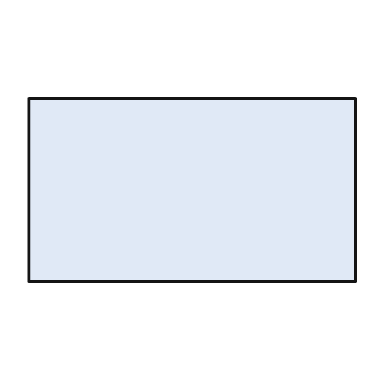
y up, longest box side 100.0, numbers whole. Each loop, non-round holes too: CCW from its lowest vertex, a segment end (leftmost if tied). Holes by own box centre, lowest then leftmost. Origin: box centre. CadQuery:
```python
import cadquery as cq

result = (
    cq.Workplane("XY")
    .moveTo(-50.0, -28.0)
    .lineTo(50.0, -28.0)
    .lineTo(50.0, 28.0)
    .lineTo(-50.0, 28.0)
    .close()
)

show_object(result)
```